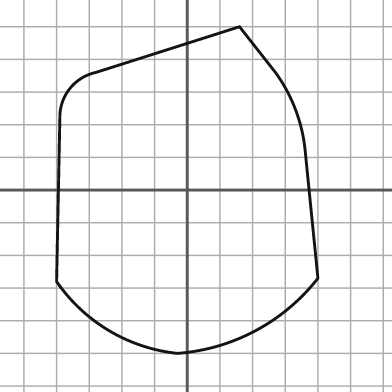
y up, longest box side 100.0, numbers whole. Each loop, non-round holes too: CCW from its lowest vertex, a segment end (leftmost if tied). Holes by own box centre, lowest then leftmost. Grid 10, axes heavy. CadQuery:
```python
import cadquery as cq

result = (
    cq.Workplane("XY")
    .moveTo(-3.0, -50.0)
    .threePointArc((21.0, -43.0), (40.0, -27.0))
    .lineTo(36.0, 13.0)
    .threePointArc((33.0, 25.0), (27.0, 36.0))
    .lineTo(16.0, 50.0)
    .lineTo(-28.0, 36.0)
    .threePointArc((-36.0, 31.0), (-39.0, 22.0))
    .lineTo(-40.0, -28.0)
    .threePointArc((-24.0, -43.0), (-3.0, -50.0))
    .close()
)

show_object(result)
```